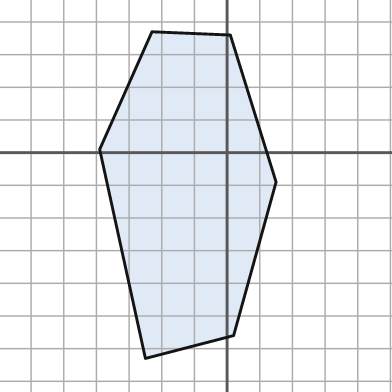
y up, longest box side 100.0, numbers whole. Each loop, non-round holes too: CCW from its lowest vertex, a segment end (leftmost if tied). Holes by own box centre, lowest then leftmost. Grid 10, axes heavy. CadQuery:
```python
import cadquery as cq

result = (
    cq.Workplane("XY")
    .moveTo(-25.0, -63.0)
    .lineTo(2.0, -56.0)
    .lineTo(15.0, -9.0)
    .lineTo(1.0, 36.0)
    .lineTo(-23.0, 37.0)
    .lineTo(-39.0, 1.0)
    .close()
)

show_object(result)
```